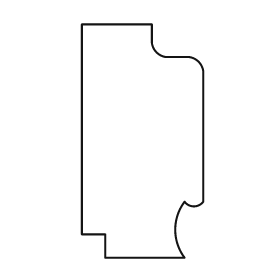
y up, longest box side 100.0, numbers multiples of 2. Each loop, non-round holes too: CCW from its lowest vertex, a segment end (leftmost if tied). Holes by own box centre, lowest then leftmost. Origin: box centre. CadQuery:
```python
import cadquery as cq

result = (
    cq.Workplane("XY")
    .moveTo(-16.0, -50.0)
    .lineTo(18.0, -50.0)
    .threePointArc((14.0, -38.0), (18.0, -26.0))
    .threePointArc((22.0, -28.0), (26.0, -26.0))
    .lineTo(26.0, 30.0)
    .threePointArc((24.0, 34.0), (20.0, 36.0))
    .lineTo(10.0, 36.0)
    .threePointArc((6.0, 38.0), (4.0, 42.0))
    .lineTo(4.0, 50.0)
    .lineTo(-26.0, 50.0)
    .lineTo(-26.0, -40.0)
    .lineTo(-16.0, -40.0)
    .close()
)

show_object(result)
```